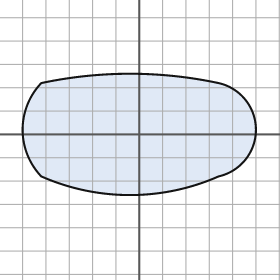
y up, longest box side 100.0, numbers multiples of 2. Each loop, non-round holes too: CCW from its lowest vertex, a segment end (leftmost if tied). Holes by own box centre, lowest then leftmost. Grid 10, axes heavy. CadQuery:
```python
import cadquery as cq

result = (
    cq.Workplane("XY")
    .moveTo(-42.0, -18.0)
    .threePointArc((-4.0, -26.0), (34.0, -18.0))
    .threePointArc((50.0, 2.0), (34.0, 22.0))
    .threePointArc((-4.0, 26.0), (-42.0, 22.0))
    .threePointArc((-50.0, 2.0), (-42.0, -18.0))
    .close()
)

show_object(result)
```